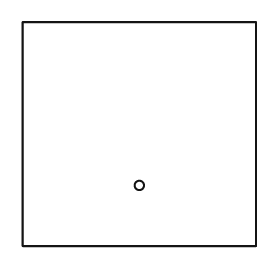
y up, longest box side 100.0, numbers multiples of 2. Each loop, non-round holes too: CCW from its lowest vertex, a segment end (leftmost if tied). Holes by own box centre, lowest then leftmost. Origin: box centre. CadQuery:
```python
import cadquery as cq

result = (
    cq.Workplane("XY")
    .moveTo(-50.0, -48.0)
    .lineTo(50.0, -48.0)
    .lineTo(50.0, 48.0)
    .lineTo(-50.0, 48.0)
    .close()
    .moveTo(0.0, -22.0)
    .circle(2.0)
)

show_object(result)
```